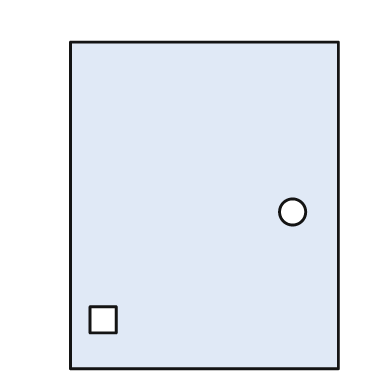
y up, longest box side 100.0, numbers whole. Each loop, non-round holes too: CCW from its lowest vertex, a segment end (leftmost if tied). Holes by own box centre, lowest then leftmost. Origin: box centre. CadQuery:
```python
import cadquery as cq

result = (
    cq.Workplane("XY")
    .moveTo(-41.0, -50.0)
    .lineTo(41.0, -50.0)
    .lineTo(41.0, 50.0)
    .lineTo(-41.0, 50.0)
    .close()
    .moveTo(-35.0, -39.0)
    .lineTo(-27.0, -39.0)
    .lineTo(-27.0, -31.0)
    .lineTo(-35.0, -31.0)
    .close()
    .moveTo(27.0, -2.0)
    .circle(4.0)
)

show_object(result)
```